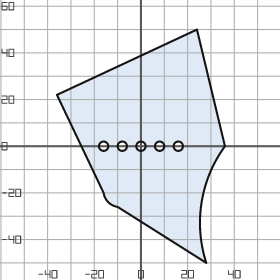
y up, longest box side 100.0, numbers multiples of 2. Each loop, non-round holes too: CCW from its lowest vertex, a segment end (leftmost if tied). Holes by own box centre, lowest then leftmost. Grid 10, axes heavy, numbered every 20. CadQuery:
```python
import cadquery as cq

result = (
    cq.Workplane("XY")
    .moveTo(28.0, -50.0)
    .threePointArc((26.0, -24.0), (36.0, 0.0))
    .lineTo(24.0, 50.0)
    .lineTo(-36.0, 22.0)
    .lineTo(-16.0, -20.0)
    .threePointArc((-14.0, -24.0), (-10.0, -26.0))
    .close()
    .moveTo(-16.0, 0.0)
    .circle(2.0)
    .moveTo(-8.0, 0.0)
    .circle(2.0)
    .moveTo(0.0, 0.0)
    .circle(2.0)
    .moveTo(8.0, 0.0)
    .circle(2.0)
    .moveTo(16.0, 0.0)
    .circle(2.0)
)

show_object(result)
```